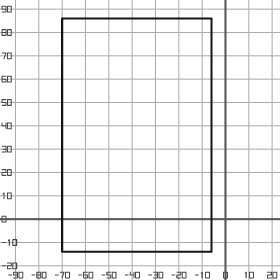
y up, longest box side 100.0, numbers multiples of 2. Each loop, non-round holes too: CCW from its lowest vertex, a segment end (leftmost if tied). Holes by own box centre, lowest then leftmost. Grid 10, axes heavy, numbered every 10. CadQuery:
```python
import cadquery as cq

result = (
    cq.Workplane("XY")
    .moveTo(-70.0, -14.0)
    .lineTo(-6.0, -14.0)
    .lineTo(-6.0, 86.0)
    .lineTo(-70.0, 86.0)
    .close()
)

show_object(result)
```